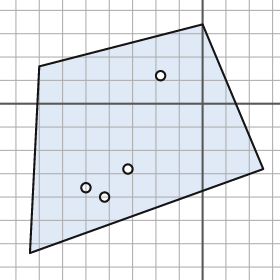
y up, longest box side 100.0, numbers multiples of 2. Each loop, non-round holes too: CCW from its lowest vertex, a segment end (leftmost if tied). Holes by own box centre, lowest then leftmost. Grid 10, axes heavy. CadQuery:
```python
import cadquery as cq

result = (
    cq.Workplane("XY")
    .moveTo(-74.0, -64.0)
    .lineTo(26.0, -28.0)
    .lineTo(0.0, 34.0)
    .lineTo(-70.0, 16.0)
    .close()
    .moveTo(-42.0, -40.0)
    .circle(2.0)
    .moveTo(-50.0, -36.0)
    .circle(2.0)
    .moveTo(-32.0, -28.0)
    .circle(2.0)
    .moveTo(-18.0, 12.0)
    .circle(2.0)
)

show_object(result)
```